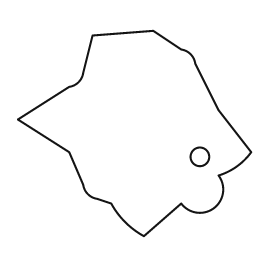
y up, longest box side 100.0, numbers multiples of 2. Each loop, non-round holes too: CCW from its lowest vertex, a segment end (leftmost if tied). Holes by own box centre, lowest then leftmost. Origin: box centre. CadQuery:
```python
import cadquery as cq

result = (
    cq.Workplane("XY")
    .moveTo(4.0, -44.0)
    .lineTo(20.0, -30.0)
    .threePointArc((34.0, -32.0), (36.0, -18.0))
    .threePointArc((44.0, -14.0), (50.0, -8.0))
    .lineTo(36.0, 10.0)
    .lineTo(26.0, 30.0)
    .threePointArc((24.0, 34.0), (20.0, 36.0))
    .lineTo(8.0, 44.0)
    .lineTo(-18.0, 42.0)
    .lineTo(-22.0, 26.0)
    .threePointArc((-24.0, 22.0), (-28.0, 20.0))
    .lineTo(-50.0, 6.0)
    .lineTo(-28.0, -8.0)
    .lineTo(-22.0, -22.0)
    .threePointArc((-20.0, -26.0), (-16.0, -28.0))
    .lineTo(-10.0, -30.0)
    .threePointArc((-4.0, -38.0), (4.0, -44.0))
    .close()
    .moveTo(28.0, -10.0)
    .circle(4.0)
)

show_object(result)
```